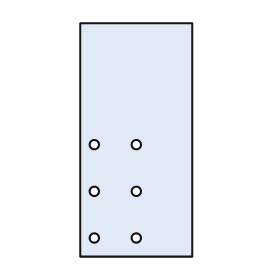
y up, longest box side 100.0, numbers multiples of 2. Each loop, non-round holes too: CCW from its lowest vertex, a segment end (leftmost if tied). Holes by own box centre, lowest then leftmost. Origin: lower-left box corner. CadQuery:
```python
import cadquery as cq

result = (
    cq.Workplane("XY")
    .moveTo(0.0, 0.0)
    .lineTo(48.0, 0.0)
    .lineTo(48.0, 100.0)
    .lineTo(0.0, 100.0)
    .close()
    .moveTo(6.0, 8.0)
    .circle(2.0)
    .moveTo(24.0, 8.0)
    .circle(2.0)
    .moveTo(6.0, 28.0)
    .circle(2.0)
    .moveTo(24.0, 28.0)
    .circle(2.0)
    .moveTo(6.0, 48.0)
    .circle(2.0)
    .moveTo(24.0, 48.0)
    .circle(2.0)
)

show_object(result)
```